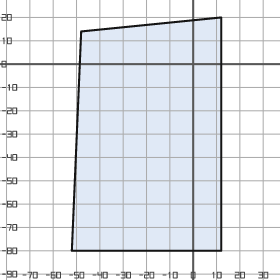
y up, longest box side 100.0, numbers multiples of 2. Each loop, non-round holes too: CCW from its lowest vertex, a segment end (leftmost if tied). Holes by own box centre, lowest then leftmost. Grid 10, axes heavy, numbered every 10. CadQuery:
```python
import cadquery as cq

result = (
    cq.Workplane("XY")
    .moveTo(-52.0, -80.0)
    .lineTo(12.0, -80.0)
    .lineTo(12.0, 20.0)
    .lineTo(-48.0, 14.0)
    .close()
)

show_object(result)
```